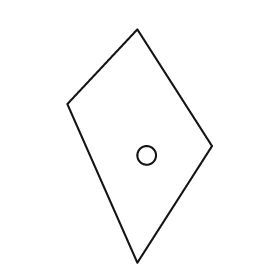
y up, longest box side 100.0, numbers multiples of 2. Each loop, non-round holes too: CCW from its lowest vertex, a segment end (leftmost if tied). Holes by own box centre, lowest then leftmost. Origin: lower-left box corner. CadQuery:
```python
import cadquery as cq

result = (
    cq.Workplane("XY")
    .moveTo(30.0, 0.0)
    .lineTo(62.0, 50.0)
    .lineTo(30.0, 100.0)
    .lineTo(0.0, 68.0)
    .close()
    .moveTo(34.0, 46.0)
    .circle(4.0)
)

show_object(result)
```